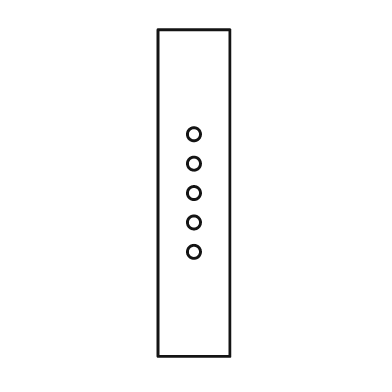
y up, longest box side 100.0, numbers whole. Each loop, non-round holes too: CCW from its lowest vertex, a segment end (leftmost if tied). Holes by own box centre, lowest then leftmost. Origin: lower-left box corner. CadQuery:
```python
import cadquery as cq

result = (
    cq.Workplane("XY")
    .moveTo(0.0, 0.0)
    .lineTo(22.0, 0.0)
    .lineTo(22.0, 100.0)
    .lineTo(0.0, 100.0)
    .close()
    .moveTo(11.0, 32.0)
    .circle(2.0)
    .moveTo(11.0, 41.0)
    .circle(2.0)
    .moveTo(11.0, 50.0)
    .circle(2.0)
    .moveTo(11.0, 59.0)
    .circle(2.0)
    .moveTo(11.0, 68.0)
    .circle(2.0)
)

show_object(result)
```